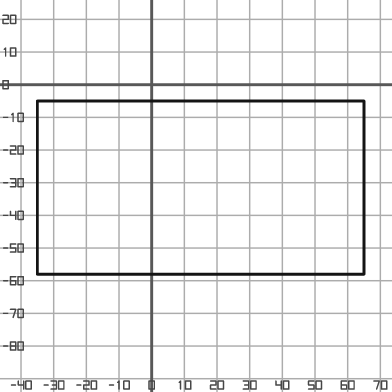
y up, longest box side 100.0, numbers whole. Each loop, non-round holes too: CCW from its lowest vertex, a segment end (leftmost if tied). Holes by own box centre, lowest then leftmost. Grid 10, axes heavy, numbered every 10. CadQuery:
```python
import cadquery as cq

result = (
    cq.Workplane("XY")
    .moveTo(-35.0, -58.0)
    .lineTo(65.0, -58.0)
    .lineTo(65.0, -5.0)
    .lineTo(-35.0, -5.0)
    .close()
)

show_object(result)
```